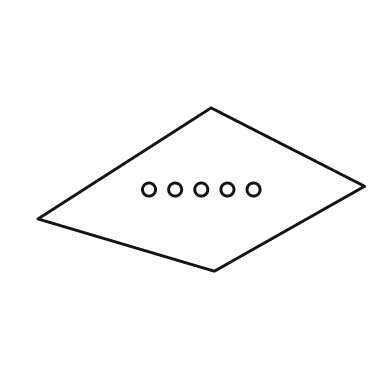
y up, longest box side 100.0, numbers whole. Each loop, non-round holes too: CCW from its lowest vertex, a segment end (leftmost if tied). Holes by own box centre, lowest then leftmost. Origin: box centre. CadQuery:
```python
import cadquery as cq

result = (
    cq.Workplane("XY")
    .moveTo(4.0, -25.0)
    .lineTo(50.0, 1.0)
    .lineTo(3.0, 25.0)
    .lineTo(-50.0, -9.0)
    .close()
    .moveTo(-16.0, 0.0)
    .circle(2.0)
    .moveTo(-8.0, 0.0)
    .circle(2.0)
    .moveTo(0.0, 0.0)
    .circle(2.0)
    .moveTo(8.0, 0.0)
    .circle(2.0)
    .moveTo(16.0, 0.0)
    .circle(2.0)
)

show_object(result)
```